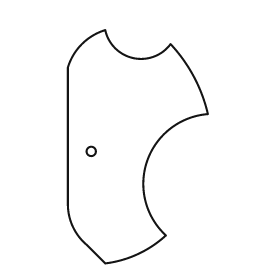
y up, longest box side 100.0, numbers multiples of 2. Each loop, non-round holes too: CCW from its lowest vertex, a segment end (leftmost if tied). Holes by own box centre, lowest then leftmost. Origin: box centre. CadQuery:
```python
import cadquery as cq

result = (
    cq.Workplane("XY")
    .moveTo(-14.0, -50.0)
    .threePointArc((0.0, -46.0), (12.0, -38.0))
    .threePointArc((4.0, -6.0), (30.0, 14.0))
    .threePointArc((24.0, 30.0), (14.0, 44.0))
    .threePointArc((-2.0, 38.0), (-14.0, 50.0))
    .threePointArc((-24.0, 44.0), (-30.0, 34.0))
    .lineTo(-30.0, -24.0)
    .threePointArc((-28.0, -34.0), (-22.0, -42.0))
    .close()
    .moveTo(-20.0, -2.0)
    .circle(2.0)
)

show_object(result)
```